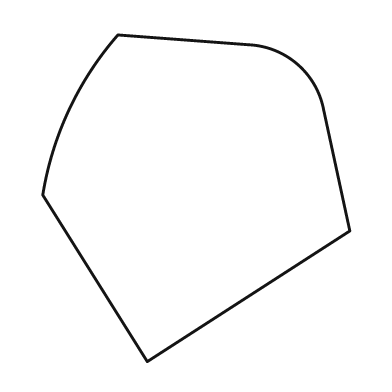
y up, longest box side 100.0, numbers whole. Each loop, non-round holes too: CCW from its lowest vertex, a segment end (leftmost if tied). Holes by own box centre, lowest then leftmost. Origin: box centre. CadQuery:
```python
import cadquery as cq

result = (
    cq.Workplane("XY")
    .moveTo(-15.0, -50.0)
    .lineTo(47.0, -10.0)
    .lineTo(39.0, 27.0)
    .threePointArc((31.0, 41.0), (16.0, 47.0))
    .lineTo(-24.0, 50.0)
    .threePointArc((-39.0, 27.0), (-47.0, 1.0))
    .close()
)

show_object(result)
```